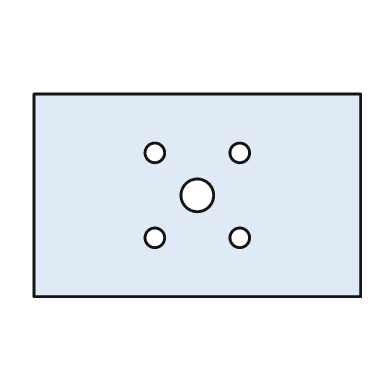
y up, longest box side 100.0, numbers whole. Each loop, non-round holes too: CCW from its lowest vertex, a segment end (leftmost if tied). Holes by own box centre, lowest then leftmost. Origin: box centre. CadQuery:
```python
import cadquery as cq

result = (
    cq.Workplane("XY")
    .moveTo(-50.0, -31.0)
    .lineTo(50.0, -31.0)
    .lineTo(50.0, 31.0)
    .lineTo(-50.0, 31.0)
    .close()
    .moveTo(-13.0, -13.0)
    .circle(3.0)
    .moveTo(13.0, -13.0)
    .circle(3.0)
    .moveTo(0.0, 0.0)
    .circle(5.0)
    .moveTo(-13.0, 13.0)
    .circle(3.0)
    .moveTo(13.0, 13.0)
    .circle(3.0)
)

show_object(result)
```